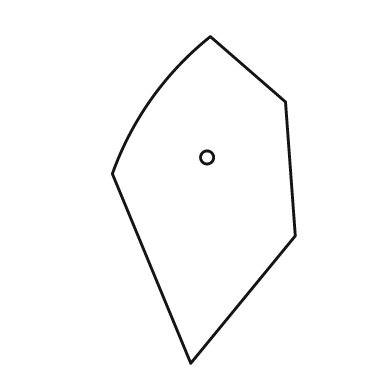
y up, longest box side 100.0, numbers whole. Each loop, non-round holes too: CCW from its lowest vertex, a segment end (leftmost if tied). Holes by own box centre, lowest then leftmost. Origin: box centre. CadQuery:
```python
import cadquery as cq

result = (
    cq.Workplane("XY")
    .moveTo(-4.0, -50.0)
    .lineTo(28.0, -11.0)
    .lineTo(25.0, 30.0)
    .lineTo(2.0, 50.0)
    .threePointArc((-16.0, 31.0), (-28.0, 8.0))
    .close()
    .moveTo(1.0, 13.0)
    .circle(2.0)
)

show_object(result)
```